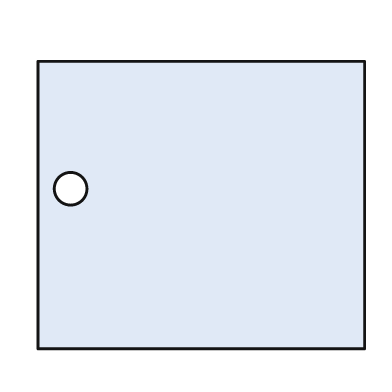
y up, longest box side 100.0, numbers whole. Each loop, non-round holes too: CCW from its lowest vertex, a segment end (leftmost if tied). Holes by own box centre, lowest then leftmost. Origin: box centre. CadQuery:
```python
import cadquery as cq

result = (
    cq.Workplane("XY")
    .moveTo(-50.0, -44.0)
    .lineTo(50.0, -44.0)
    .lineTo(50.0, 44.0)
    .lineTo(-50.0, 44.0)
    .close()
    .moveTo(-40.0, 5.0)
    .circle(5.0)
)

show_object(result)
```